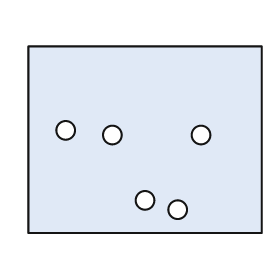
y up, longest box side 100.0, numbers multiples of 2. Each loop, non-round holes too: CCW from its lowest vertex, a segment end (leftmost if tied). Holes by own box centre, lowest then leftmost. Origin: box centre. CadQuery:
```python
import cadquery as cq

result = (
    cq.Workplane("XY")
    .moveTo(-50.0, -40.0)
    .lineTo(50.0, -40.0)
    .lineTo(50.0, 40.0)
    .lineTo(-50.0, 40.0)
    .close()
    .moveTo(14.0, -30.0)
    .circle(4.0)
    .moveTo(0.0, -26.0)
    .circle(4.0)
    .moveTo(-14.0, 2.0)
    .circle(4.0)
    .moveTo(24.0, 2.0)
    .circle(4.0)
    .moveTo(-34.0, 4.0)
    .circle(4.0)
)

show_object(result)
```